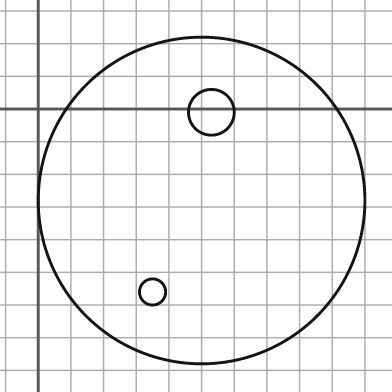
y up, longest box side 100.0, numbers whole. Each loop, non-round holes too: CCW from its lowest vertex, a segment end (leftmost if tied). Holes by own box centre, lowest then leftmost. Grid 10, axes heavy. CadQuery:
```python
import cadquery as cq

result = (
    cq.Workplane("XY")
    .moveTo(50.0, -28.0)
    .circle(50.0)
    .moveTo(35.0, -56.0)
    .circle(4.0)
    .moveTo(53.0, -1.0)
    .circle(7.0)
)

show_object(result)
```